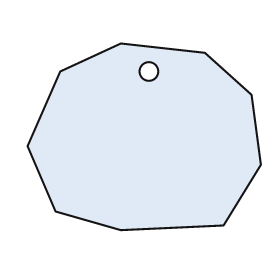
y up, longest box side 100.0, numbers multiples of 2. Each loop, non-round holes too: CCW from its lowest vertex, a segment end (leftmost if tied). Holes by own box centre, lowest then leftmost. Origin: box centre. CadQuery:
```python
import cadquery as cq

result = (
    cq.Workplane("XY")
    .moveTo(-10.0, -40.0)
    .lineTo(34.0, -38.0)
    .lineTo(50.0, -12.0)
    .lineTo(46.0, 18.0)
    .lineTo(26.0, 36.0)
    .lineTo(-10.0, 40.0)
    .lineTo(-36.0, 28.0)
    .lineTo(-50.0, -4.0)
    .lineTo(-38.0, -32.0)
    .close()
    .moveTo(2.0, 28.0)
    .circle(4.0)
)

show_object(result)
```